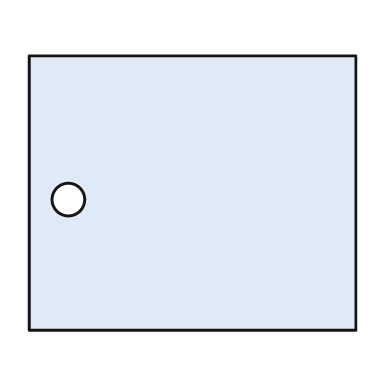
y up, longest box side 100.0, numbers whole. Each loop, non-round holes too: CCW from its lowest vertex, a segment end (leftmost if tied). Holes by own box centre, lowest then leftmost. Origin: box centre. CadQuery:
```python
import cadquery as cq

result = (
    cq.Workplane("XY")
    .moveTo(-50.0, -42.0)
    .lineTo(50.0, -42.0)
    .lineTo(50.0, 42.0)
    .lineTo(-50.0, 42.0)
    .close()
    .moveTo(-38.0, -2.0)
    .circle(5.0)
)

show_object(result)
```